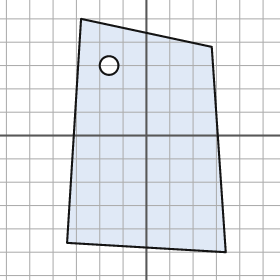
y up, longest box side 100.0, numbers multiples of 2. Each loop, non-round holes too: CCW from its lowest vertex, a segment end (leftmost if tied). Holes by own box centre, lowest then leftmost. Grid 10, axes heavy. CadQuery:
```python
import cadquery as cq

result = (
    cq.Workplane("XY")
    .moveTo(34.0, -50.0)
    .lineTo(28.0, 38.0)
    .lineTo(-28.0, 50.0)
    .lineTo(-34.0, -46.0)
    .close()
    .moveTo(-16.0, 30.0)
    .circle(4.0)
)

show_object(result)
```